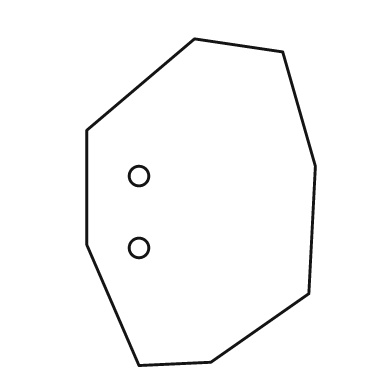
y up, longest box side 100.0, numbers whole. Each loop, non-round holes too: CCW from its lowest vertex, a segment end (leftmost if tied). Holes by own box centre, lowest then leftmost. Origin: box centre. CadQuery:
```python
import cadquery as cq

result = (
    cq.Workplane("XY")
    .moveTo(-19.0, -50.0)
    .lineTo(3.0, -49.0)
    .lineTo(33.0, -28.0)
    .lineTo(35.0, 11.0)
    .lineTo(25.0, 46.0)
    .lineTo(-2.0, 50.0)
    .lineTo(-35.0, 22.0)
    .lineTo(-35.0, -13.0)
    .close()
    .moveTo(-19.0, -14.0)
    .circle(3.0)
    .moveTo(-19.0, 8.0)
    .circle(3.0)
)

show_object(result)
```